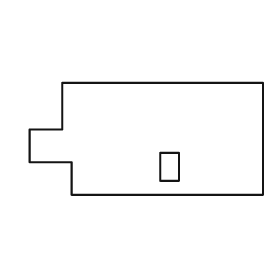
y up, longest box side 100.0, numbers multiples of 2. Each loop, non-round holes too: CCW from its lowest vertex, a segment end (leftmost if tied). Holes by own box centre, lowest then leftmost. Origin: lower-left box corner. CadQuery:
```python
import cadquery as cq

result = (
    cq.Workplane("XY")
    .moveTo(18.0, 0.0)
    .lineTo(100.0, 0.0)
    .lineTo(100.0, 48.0)
    .lineTo(14.0, 48.0)
    .lineTo(14.0, 28.0)
    .lineTo(0.0, 28.0)
    .lineTo(0.0, 14.0)
    .lineTo(18.0, 14.0)
    .close()
    .moveTo(56.0, 6.0)
    .lineTo(64.0, 6.0)
    .lineTo(64.0, 18.0)
    .lineTo(56.0, 18.0)
    .close()
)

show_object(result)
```